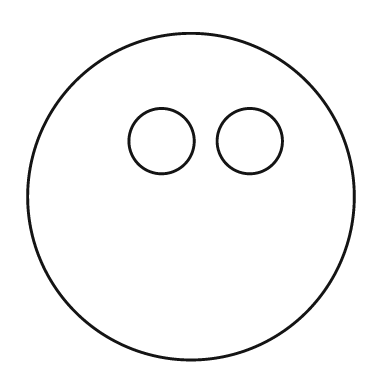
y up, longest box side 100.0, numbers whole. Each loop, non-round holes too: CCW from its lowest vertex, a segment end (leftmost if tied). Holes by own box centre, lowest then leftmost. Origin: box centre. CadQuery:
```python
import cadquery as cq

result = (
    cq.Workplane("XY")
    .moveTo(0.0, 0.0)
    .circle(50.0)
    .moveTo(-9.0, 17.0)
    .circle(10.0)
    .moveTo(18.0, 17.0)
    .circle(10.0)
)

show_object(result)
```